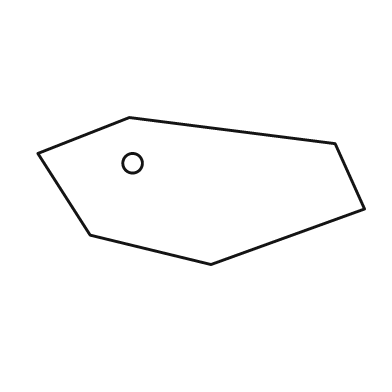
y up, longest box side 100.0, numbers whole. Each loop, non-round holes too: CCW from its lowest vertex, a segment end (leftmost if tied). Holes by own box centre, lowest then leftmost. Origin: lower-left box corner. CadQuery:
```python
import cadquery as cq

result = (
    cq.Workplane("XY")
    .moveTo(53.0, 0.0)
    .lineTo(100.0, 17.0)
    .lineTo(91.0, 37.0)
    .lineTo(28.0, 45.0)
    .lineTo(0.0, 34.0)
    .lineTo(16.0, 9.0)
    .close()
    .moveTo(29.0, 31.0)
    .circle(3.0)
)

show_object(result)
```